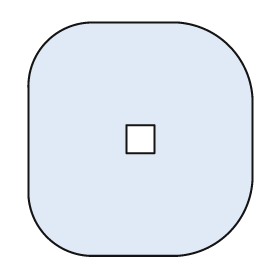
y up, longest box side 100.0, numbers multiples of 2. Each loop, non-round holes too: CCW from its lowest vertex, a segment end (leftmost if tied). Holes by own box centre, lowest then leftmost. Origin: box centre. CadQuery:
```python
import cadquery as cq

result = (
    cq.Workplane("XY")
    .moveTo(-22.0, -50.0)
    .lineTo(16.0, -50.0)
    .threePointArc((38.0, -40.0), (48.0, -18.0))
    .lineTo(48.0, 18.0)
    .threePointArc((38.0, 40.0), (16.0, 50.0))
    .lineTo(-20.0, 50.0)
    .threePointArc((-40.0, 42.0), (-48.0, 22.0))
    .lineTo(-48.0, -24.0)
    .threePointArc((-40.0, -42.0), (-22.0, -50.0))
    .close()
    .moveTo(-6.0, -6.0)
    .lineTo(6.0, -6.0)
    .lineTo(6.0, 6.0)
    .lineTo(-6.0, 6.0)
    .close()
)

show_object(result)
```